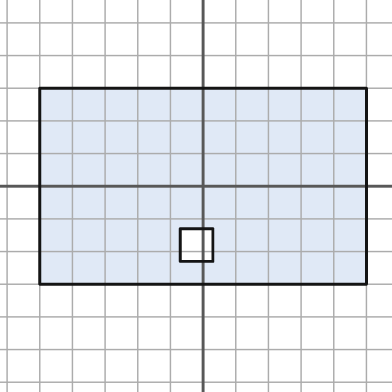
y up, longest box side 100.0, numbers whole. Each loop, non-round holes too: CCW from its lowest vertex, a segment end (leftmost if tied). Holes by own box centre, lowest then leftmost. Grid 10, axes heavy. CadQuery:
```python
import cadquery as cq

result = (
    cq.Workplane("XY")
    .moveTo(-50.0, -30.0)
    .lineTo(50.0, -30.0)
    .lineTo(50.0, 30.0)
    .lineTo(-50.0, 30.0)
    .close()
    .moveTo(-7.0, -23.0)
    .lineTo(3.0, -23.0)
    .lineTo(3.0, -13.0)
    .lineTo(-7.0, -13.0)
    .close()
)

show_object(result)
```